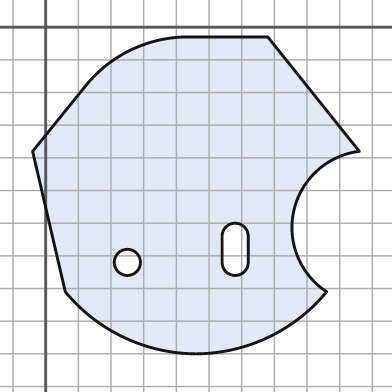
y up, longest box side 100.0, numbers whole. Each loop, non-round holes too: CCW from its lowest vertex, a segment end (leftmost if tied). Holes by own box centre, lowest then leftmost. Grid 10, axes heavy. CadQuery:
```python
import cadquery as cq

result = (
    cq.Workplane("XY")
    .moveTo(46.0, -100.0)
    .threePointArc((68.0, -95.0), (86.0, -81.0))
    .threePointArc((76.0, -56.0), (96.0, -38.0))
    .lineTo(68.0, -3.0)
    .lineTo(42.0, -3.0)
    .threePointArc((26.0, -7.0), (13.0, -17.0))
    .lineTo(-4.0, -38.0)
    .lineTo(6.0, -81.0)
    .threePointArc((24.0, -95.0), (46.0, -100.0))
    .close()
    .moveTo(25.0, -72.0)
    .circle(4.0)
    .moveTo(54.0, -72.0)
    .threePointArc((58.0, -76.0), (62.0, -72.0))
    .lineTo(62.0, -64.0)
    .threePointArc((58.0, -60.0), (54.0, -64.0))
    .close()
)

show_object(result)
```